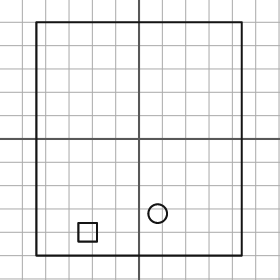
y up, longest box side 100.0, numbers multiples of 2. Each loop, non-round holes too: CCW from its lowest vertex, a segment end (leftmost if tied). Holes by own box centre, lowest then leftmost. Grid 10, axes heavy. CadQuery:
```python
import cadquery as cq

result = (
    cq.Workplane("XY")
    .moveTo(-44.0, -50.0)
    .lineTo(44.0, -50.0)
    .lineTo(44.0, 50.0)
    .lineTo(-44.0, 50.0)
    .close()
    .moveTo(-26.0, -44.0)
    .lineTo(-18.0, -44.0)
    .lineTo(-18.0, -36.0)
    .lineTo(-26.0, -36.0)
    .close()
    .moveTo(8.0, -32.0)
    .circle(4.0)
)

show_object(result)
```